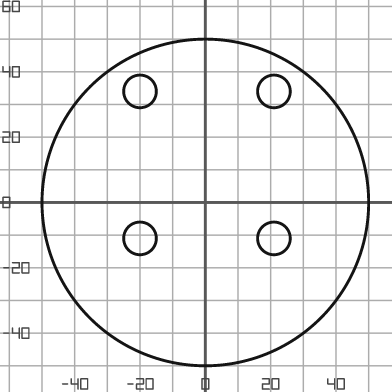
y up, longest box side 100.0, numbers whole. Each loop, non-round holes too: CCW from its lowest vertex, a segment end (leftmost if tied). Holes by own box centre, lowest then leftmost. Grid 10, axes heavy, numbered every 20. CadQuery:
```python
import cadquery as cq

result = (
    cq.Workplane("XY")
    .moveTo(0.0, 0.0)
    .circle(50.0)
    .moveTo(-20.0, -11.0)
    .circle(5.0)
    .moveTo(21.0, -11.0)
    .circle(5.0)
    .moveTo(-20.0, 34.0)
    .circle(5.0)
    .moveTo(21.0, 34.0)
    .circle(5.0)
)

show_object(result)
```